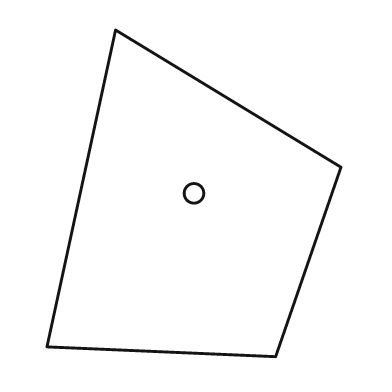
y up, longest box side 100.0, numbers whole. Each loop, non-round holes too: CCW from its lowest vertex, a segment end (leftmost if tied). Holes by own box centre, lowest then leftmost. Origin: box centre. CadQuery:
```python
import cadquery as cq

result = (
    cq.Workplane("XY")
    .moveTo(25.0, -50.0)
    .lineTo(45.0, 8.0)
    .lineTo(-24.0, 50.0)
    .lineTo(-45.0, -47.0)
    .close()
    .moveTo(0.0, 0.0)
    .circle(3.0)
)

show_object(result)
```